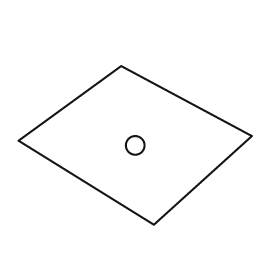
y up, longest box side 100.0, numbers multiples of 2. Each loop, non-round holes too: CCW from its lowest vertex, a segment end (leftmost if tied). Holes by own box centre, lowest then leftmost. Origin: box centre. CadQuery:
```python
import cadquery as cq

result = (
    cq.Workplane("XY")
    .moveTo(8.0, -34.0)
    .lineTo(50.0, 4.0)
    .lineTo(-6.0, 34.0)
    .lineTo(-50.0, 2.0)
    .close()
    .moveTo(0.0, 0.0)
    .circle(4.0)
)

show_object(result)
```